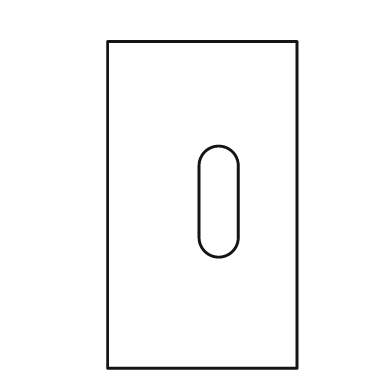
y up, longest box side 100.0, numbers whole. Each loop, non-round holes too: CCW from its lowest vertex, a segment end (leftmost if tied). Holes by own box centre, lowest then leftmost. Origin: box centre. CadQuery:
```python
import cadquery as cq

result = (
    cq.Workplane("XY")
    .moveTo(-29.0, -50.0)
    .lineTo(29.0, -50.0)
    .lineTo(29.0, 50.0)
    .lineTo(-29.0, 50.0)
    .close()
    .moveTo(-1.0, -10.0)
    .threePointArc((5.0, -16.0), (11.0, -10.0))
    .lineTo(11.0, 12.0)
    .threePointArc((5.0, 18.0), (-1.0, 12.0))
    .close()
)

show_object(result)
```